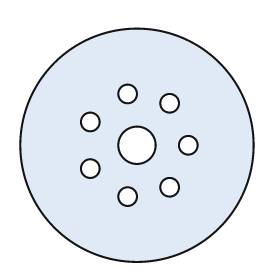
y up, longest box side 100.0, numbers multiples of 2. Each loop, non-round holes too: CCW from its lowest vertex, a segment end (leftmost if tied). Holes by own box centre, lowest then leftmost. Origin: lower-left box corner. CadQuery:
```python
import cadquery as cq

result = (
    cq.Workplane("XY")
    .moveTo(50.0, 50.0)
    .circle(50.0)
    .moveTo(46.0, 28.0)
    .circle(4.0)
    .moveTo(64.0, 32.0)
    .circle(4.0)
    .moveTo(30.0, 40.0)
    .circle(4.0)
    .moveTo(50.0, 50.0)
    .circle(8.0)
    .moveTo(72.0, 50.0)
    .circle(4.0)
    .moveTo(30.0, 60.0)
    .circle(4.0)
    .moveTo(64.0, 68.0)
    .circle(4.0)
    .moveTo(46.0, 72.0)
    .circle(4.0)
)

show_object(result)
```